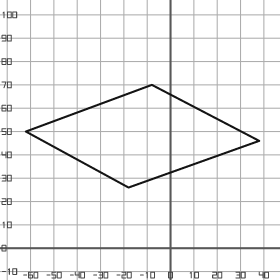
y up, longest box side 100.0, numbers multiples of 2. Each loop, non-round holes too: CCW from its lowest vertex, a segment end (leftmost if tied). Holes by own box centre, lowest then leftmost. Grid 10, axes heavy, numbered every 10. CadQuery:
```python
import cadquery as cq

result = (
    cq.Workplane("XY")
    .moveTo(-18.0, 26.0)
    .lineTo(38.0, 46.0)
    .lineTo(-8.0, 70.0)
    .lineTo(-62.0, 50.0)
    .close()
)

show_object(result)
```